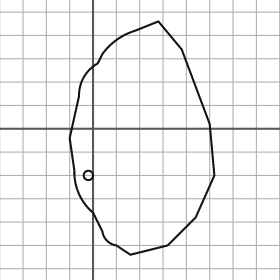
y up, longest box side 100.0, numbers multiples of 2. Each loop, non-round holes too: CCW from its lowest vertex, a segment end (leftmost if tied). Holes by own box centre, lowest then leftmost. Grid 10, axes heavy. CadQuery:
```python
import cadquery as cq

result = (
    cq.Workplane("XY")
    .moveTo(16.0, -54.0)
    .lineTo(32.0, -50.0)
    .lineTo(44.0, -38.0)
    .lineTo(52.0, -20.0)
    .lineTo(50.0, 2.0)
    .lineTo(38.0, 34.0)
    .lineTo(28.0, 46.0)
    .lineTo(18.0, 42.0)
    .threePointArc((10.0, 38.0), (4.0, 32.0))
    .lineTo(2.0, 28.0)
    .threePointArc((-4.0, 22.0), (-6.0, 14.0))
    .lineTo(-10.0, -4.0)
    .lineTo(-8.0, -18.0)
    .threePointArc((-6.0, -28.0), (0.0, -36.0))
    .lineTo(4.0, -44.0)
    .threePointArc((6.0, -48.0), (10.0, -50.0))
    .close()
    .moveTo(-2.0, -20.0)
    .circle(2.0)
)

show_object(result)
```